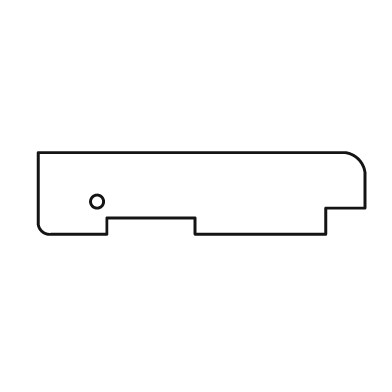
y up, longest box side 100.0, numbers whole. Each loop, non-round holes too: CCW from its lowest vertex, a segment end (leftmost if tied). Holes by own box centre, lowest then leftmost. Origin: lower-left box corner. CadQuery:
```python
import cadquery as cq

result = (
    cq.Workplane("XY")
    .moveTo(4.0, 0.0)
    .lineTo(21.0, 0.0)
    .lineTo(21.0, 5.0)
    .lineTo(48.0, 5.0)
    .lineTo(48.0, 0.0)
    .lineTo(88.0, 0.0)
    .lineTo(88.0, 8.0)
    .lineTo(100.0, 8.0)
    .lineTo(100.0, 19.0)
    .threePointArc((98.0, 23.0), (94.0, 25.0))
    .lineTo(0.0, 25.0)
    .lineTo(0.0, 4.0)
    .threePointArc((1.0, 1.0), (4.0, 0.0))
    .close()
    .moveTo(18.0, 10.0)
    .circle(2.0)
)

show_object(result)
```